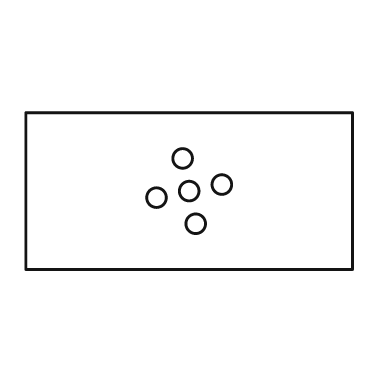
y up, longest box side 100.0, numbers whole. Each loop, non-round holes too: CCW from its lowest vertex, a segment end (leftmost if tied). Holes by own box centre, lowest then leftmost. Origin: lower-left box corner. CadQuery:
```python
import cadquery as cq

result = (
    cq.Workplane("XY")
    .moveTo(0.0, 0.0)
    .lineTo(100.0, 0.0)
    .lineTo(100.0, 48.0)
    .lineTo(0.0, 48.0)
    .close()
    .moveTo(52.0, 14.0)
    .circle(3.0)
    .moveTo(40.0, 22.0)
    .circle(3.0)
    .moveTo(50.0, 24.0)
    .circle(3.0)
    .moveTo(60.0, 26.0)
    .circle(3.0)
    .moveTo(48.0, 34.0)
    .circle(3.0)
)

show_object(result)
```